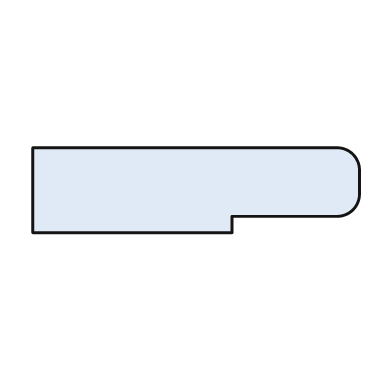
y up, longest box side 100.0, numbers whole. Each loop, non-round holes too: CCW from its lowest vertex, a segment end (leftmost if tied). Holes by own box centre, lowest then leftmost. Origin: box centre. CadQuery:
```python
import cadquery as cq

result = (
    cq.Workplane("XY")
    .moveTo(-50.0, -13.0)
    .lineTo(11.0, -13.0)
    .lineTo(11.0, -8.0)
    .lineTo(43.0, -8.0)
    .threePointArc((48.0, -6.0), (50.0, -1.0))
    .lineTo(50.0, 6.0)
    .threePointArc((48.0, 11.0), (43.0, 13.0))
    .lineTo(-50.0, 13.0)
    .close()
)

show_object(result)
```